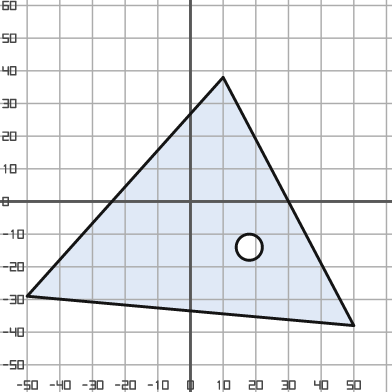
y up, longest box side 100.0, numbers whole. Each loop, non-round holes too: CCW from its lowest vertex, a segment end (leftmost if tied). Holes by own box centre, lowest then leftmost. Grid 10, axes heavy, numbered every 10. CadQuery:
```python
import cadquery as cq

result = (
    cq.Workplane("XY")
    .moveTo(50.0, -38.0)
    .lineTo(10.0, 38.0)
    .lineTo(-50.0, -29.0)
    .close()
    .moveTo(18.0, -14.0)
    .circle(4.0)
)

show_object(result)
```